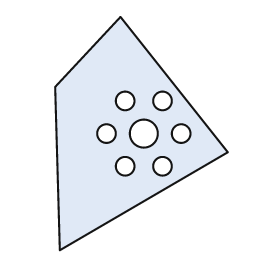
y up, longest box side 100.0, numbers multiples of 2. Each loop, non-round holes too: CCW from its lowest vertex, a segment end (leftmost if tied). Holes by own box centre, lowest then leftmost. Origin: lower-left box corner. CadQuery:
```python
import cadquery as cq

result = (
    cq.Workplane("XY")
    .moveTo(2.0, 0.0)
    .lineTo(74.0, 42.0)
    .lineTo(28.0, 100.0)
    .lineTo(0.0, 70.0)
    .close()
    .moveTo(30.0, 36.0)
    .circle(4.0)
    .moveTo(46.0, 36.0)
    .circle(4.0)
    .moveTo(22.0, 50.0)
    .circle(4.0)
    .moveTo(38.0, 50.0)
    .circle(6.0)
    .moveTo(54.0, 50.0)
    .circle(4.0)
    .moveTo(30.0, 64.0)
    .circle(4.0)
    .moveTo(46.0, 64.0)
    .circle(4.0)
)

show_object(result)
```